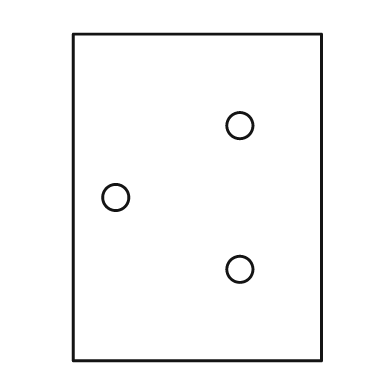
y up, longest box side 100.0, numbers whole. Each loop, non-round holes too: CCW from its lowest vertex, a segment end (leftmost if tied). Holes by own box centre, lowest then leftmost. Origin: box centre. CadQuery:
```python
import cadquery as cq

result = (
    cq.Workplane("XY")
    .moveTo(-38.0, -50.0)
    .lineTo(38.0, -50.0)
    .lineTo(38.0, 50.0)
    .lineTo(-38.0, 50.0)
    .close()
    .moveTo(13.0, -22.0)
    .circle(4.0)
    .moveTo(-25.0, 0.0)
    .circle(4.0)
    .moveTo(13.0, 22.0)
    .circle(4.0)
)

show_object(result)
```